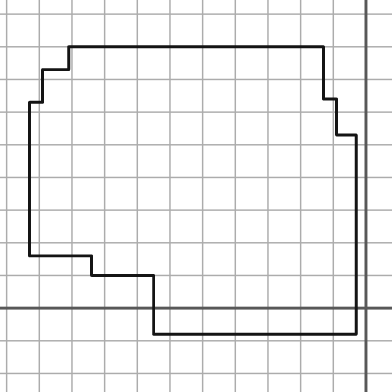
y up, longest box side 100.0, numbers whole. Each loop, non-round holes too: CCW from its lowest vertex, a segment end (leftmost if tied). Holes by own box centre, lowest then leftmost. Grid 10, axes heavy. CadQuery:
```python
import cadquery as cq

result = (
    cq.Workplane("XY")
    .moveTo(-65.0, -8.0)
    .lineTo(-3.0, -8.0)
    .lineTo(-3.0, 53.0)
    .lineTo(-9.0, 53.0)
    .lineTo(-9.0, 64.0)
    .lineTo(-13.0, 64.0)
    .lineTo(-13.0, 80.0)
    .lineTo(-91.0, 80.0)
    .lineTo(-91.0, 73.0)
    .lineTo(-99.0, 73.0)
    .lineTo(-99.0, 63.0)
    .lineTo(-103.0, 63.0)
    .lineTo(-103.0, 16.0)
    .lineTo(-84.0, 16.0)
    .lineTo(-84.0, 10.0)
    .lineTo(-65.0, 10.0)
    .close()
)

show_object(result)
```